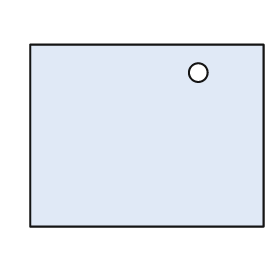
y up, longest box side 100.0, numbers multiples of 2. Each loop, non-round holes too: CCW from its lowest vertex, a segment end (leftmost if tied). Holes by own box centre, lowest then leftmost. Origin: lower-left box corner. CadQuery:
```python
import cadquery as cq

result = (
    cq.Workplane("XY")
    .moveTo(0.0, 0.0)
    .lineTo(100.0, 0.0)
    .lineTo(100.0, 78.0)
    .lineTo(0.0, 78.0)
    .close()
    .moveTo(72.0, 66.0)
    .circle(4.0)
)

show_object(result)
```